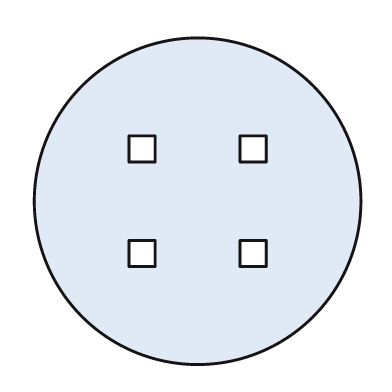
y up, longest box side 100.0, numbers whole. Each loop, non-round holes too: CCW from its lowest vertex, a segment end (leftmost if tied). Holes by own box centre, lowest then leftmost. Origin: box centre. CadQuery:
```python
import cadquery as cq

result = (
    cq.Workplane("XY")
    .moveTo(0.0, 0.0)
    .circle(50.0)
    .moveTo(-21.0, -20.0)
    .lineTo(-13.0, -20.0)
    .lineTo(-13.0, -12.0)
    .lineTo(-21.0, -12.0)
    .close()
    .moveTo(13.0, -20.0)
    .lineTo(21.0, -20.0)
    .lineTo(21.0, -12.0)
    .lineTo(13.0, -12.0)
    .close()
    .moveTo(-21.0, 12.0)
    .lineTo(-13.0, 12.0)
    .lineTo(-13.0, 20.0)
    .lineTo(-21.0, 20.0)
    .close()
    .moveTo(13.0, 12.0)
    .lineTo(21.0, 12.0)
    .lineTo(21.0, 20.0)
    .lineTo(13.0, 20.0)
    .close()
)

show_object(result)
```